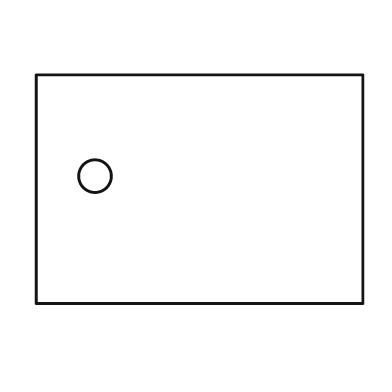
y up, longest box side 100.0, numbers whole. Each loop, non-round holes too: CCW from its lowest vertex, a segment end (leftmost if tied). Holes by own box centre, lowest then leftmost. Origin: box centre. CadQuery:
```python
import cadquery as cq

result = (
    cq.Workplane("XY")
    .moveTo(-50.0, -35.0)
    .lineTo(50.0, -35.0)
    .lineTo(50.0, 35.0)
    .lineTo(-50.0, 35.0)
    .close()
    .moveTo(-32.0, 4.0)
    .circle(5.0)
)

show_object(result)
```